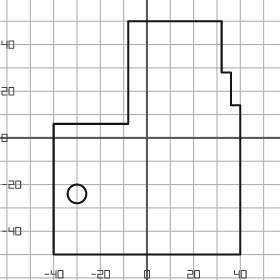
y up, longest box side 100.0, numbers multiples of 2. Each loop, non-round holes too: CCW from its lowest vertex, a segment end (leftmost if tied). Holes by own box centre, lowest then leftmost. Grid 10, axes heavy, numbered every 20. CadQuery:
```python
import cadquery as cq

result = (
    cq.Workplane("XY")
    .moveTo(-40.0, -50.0)
    .lineTo(40.0, -50.0)
    .lineTo(40.0, 14.0)
    .lineTo(36.0, 14.0)
    .lineTo(36.0, 28.0)
    .lineTo(32.0, 28.0)
    .lineTo(32.0, 50.0)
    .lineTo(-8.0, 50.0)
    .lineTo(-8.0, 6.0)
    .lineTo(-40.0, 6.0)
    .close()
    .moveTo(-30.0, -24.0)
    .circle(4.0)
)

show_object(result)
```